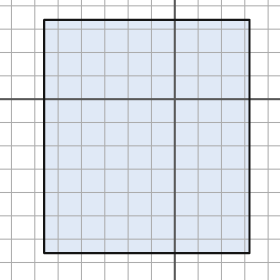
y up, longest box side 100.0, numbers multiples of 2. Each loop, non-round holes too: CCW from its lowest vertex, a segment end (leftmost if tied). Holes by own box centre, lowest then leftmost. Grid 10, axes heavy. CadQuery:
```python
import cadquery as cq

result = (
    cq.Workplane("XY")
    .moveTo(-56.0, -66.0)
    .lineTo(32.0, -66.0)
    .lineTo(32.0, 34.0)
    .lineTo(-56.0, 34.0)
    .close()
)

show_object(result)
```